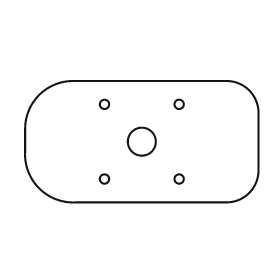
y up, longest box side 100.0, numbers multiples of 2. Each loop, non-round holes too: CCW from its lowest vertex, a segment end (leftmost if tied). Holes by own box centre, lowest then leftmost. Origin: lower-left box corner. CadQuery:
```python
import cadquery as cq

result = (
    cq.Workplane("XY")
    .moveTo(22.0, 0.0)
    .lineTo(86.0, 0.0)
    .threePointArc((96.0, 4.0), (100.0, 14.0))
    .lineTo(100.0, 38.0)
    .threePointArc((96.0, 48.0), (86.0, 52.0))
    .lineTo(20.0, 52.0)
    .threePointArc((6.0, 46.0), (0.0, 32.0))
    .lineTo(0.0, 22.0)
    .threePointArc((6.0, 6.0), (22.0, 0.0))
    .close()
    .moveTo(34.0, 10.0)
    .circle(2.0)
    .moveTo(66.0, 10.0)
    .circle(2.0)
    .moveTo(50.0, 26.0)
    .circle(6.0)
    .moveTo(34.0, 42.0)
    .circle(2.0)
    .moveTo(66.0, 42.0)
    .circle(2.0)
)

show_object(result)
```